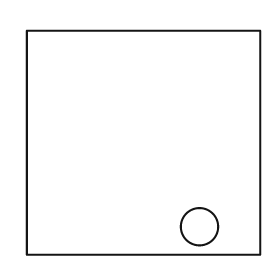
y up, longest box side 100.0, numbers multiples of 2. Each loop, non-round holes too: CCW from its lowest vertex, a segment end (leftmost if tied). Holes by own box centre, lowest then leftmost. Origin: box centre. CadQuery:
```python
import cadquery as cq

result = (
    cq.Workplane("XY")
    .moveTo(-50.0, -48.0)
    .lineTo(50.0, -48.0)
    .lineTo(50.0, 48.0)
    .lineTo(-50.0, 48.0)
    .close()
    .moveTo(24.0, -36.0)
    .circle(8.0)
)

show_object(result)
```